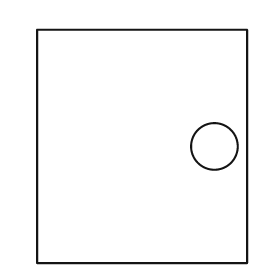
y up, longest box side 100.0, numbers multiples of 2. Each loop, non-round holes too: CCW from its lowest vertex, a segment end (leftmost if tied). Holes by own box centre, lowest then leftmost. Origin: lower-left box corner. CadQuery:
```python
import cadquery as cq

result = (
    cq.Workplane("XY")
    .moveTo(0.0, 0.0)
    .lineTo(90.0, 0.0)
    .lineTo(90.0, 100.0)
    .lineTo(0.0, 100.0)
    .close()
    .moveTo(76.0, 50.0)
    .circle(10.0)
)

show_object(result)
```